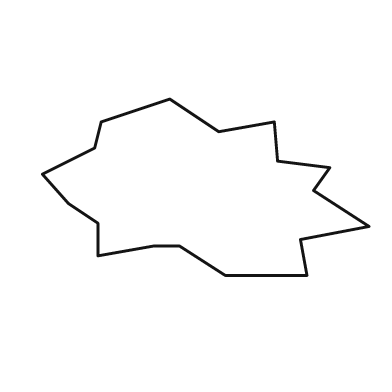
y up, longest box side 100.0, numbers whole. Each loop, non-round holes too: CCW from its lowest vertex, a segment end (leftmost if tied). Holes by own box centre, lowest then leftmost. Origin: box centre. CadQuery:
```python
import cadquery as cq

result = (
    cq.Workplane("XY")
    .moveTo(6.0, -27.0)
    .lineTo(31.0, -27.0)
    .lineTo(29.0, -16.0)
    .lineTo(50.0, -12.0)
    .lineTo(33.0, -1.0)
    .lineTo(38.0, 6.0)
    .lineTo(22.0, 8.0)
    .lineTo(21.0, 20.0)
    .lineTo(4.0, 17.0)
    .lineTo(-11.0, 27.0)
    .lineTo(-32.0, 20.0)
    .lineTo(-34.0, 12.0)
    .lineTo(-50.0, 4.0)
    .lineTo(-42.0, -5.0)
    .lineTo(-33.0, -11.0)
    .lineTo(-33.0, -21.0)
    .lineTo(-16.0, -18.0)
    .lineTo(-8.0, -18.0)
    .close()
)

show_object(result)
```